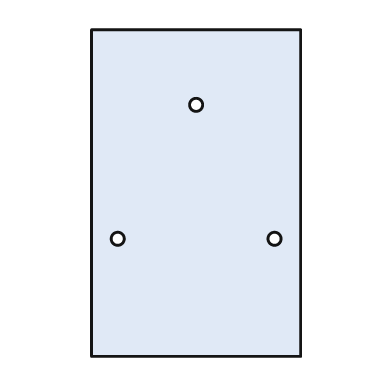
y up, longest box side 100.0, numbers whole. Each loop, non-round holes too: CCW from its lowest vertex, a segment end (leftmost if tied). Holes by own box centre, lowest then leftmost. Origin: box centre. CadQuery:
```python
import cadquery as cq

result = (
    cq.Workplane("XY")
    .moveTo(-32.0, -50.0)
    .lineTo(32.0, -50.0)
    .lineTo(32.0, 50.0)
    .lineTo(-32.0, 50.0)
    .close()
    .moveTo(-24.0, -14.0)
    .circle(2.0)
    .moveTo(24.0, -14.0)
    .circle(2.0)
    .moveTo(0.0, 27.0)
    .circle(2.0)
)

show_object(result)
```